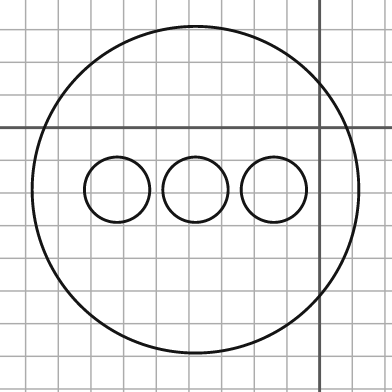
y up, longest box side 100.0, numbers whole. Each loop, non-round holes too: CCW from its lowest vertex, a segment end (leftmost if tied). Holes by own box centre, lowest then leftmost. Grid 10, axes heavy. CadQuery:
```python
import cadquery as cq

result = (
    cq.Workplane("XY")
    .moveTo(-38.0, -19.0)
    .circle(50.0)
    .moveTo(-62.0, -19.0)
    .circle(10.0)
    .moveTo(-38.0, -19.0)
    .circle(10.0)
    .moveTo(-14.0, -19.0)
    .circle(10.0)
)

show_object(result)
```